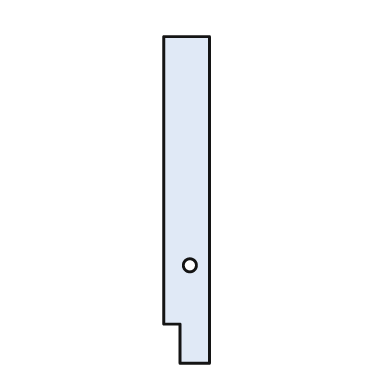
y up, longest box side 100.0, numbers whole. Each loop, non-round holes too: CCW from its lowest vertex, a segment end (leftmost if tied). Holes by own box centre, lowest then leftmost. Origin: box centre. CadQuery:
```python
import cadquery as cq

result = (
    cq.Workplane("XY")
    .moveTo(-2.0, -50.0)
    .lineTo(7.0, -50.0)
    .lineTo(7.0, 50.0)
    .lineTo(-7.0, 50.0)
    .lineTo(-7.0, -38.0)
    .lineTo(-2.0, -38.0)
    .close()
    .moveTo(1.0, -20.0)
    .circle(2.0)
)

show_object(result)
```